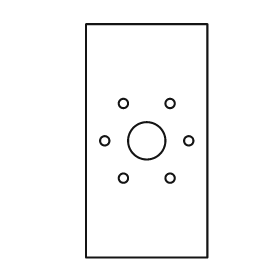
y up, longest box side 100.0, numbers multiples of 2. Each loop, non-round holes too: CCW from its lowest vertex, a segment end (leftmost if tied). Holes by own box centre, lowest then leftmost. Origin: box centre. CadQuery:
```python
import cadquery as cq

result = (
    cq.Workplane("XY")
    .moveTo(-26.0, -50.0)
    .lineTo(26.0, -50.0)
    .lineTo(26.0, 50.0)
    .lineTo(-26.0, 50.0)
    .close()
    .moveTo(-10.0, -16.0)
    .circle(2.0)
    .moveTo(10.0, -16.0)
    .circle(2.0)
    .moveTo(-18.0, 0.0)
    .circle(2.0)
    .moveTo(0.0, 0.0)
    .circle(8.0)
    .moveTo(18.0, 0.0)
    .circle(2.0)
    .moveTo(-10.0, 16.0)
    .circle(2.0)
    .moveTo(10.0, 16.0)
    .circle(2.0)
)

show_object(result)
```